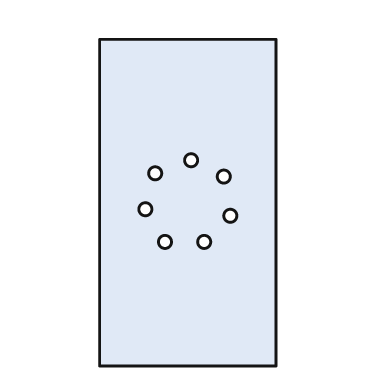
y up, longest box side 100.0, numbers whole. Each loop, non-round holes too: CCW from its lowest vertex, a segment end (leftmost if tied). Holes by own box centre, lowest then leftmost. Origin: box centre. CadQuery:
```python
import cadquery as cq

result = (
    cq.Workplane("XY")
    .moveTo(-27.0, -50.0)
    .lineTo(27.0, -50.0)
    .lineTo(27.0, 50.0)
    .lineTo(-27.0, 50.0)
    .close()
    .moveTo(-7.0, -12.0)
    .circle(2.0)
    .moveTo(5.0, -12.0)
    .circle(2.0)
    .moveTo(13.0, -4.0)
    .circle(2.0)
    .moveTo(-13.0, -2.0)
    .circle(2.0)
    .moveTo(11.0, 8.0)
    .circle(2.0)
    .moveTo(-10.0, 9.0)
    .circle(2.0)
    .moveTo(1.0, 13.0)
    .circle(2.0)
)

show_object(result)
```